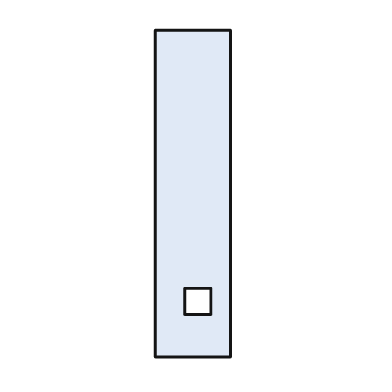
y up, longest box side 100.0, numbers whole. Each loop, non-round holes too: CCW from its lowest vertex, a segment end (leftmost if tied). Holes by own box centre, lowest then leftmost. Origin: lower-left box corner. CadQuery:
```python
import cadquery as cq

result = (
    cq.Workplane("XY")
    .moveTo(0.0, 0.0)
    .lineTo(23.0, 0.0)
    .lineTo(23.0, 100.0)
    .lineTo(0.0, 100.0)
    .close()
    .moveTo(9.0, 13.0)
    .lineTo(17.0, 13.0)
    .lineTo(17.0, 21.0)
    .lineTo(9.0, 21.0)
    .close()
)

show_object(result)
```